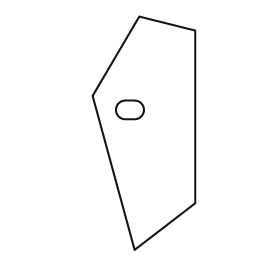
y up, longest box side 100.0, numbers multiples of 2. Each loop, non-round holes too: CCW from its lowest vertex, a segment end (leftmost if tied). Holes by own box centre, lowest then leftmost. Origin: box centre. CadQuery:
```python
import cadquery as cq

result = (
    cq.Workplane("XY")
    .moveTo(-4.0, -50.0)
    .lineTo(22.0, -30.0)
    .lineTo(22.0, 44.0)
    .lineTo(-2.0, 50.0)
    .lineTo(-22.0, 16.0)
    .close()
    .moveTo(-8.0, 6.0)
    .lineTo(-4.0, 6.0)
    .threePointArc((0.0, 10.0), (-4.0, 14.0))
    .lineTo(-8.0, 14.0)
    .threePointArc((-12.0, 10.0), (-8.0, 6.0))
    .close()
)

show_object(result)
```